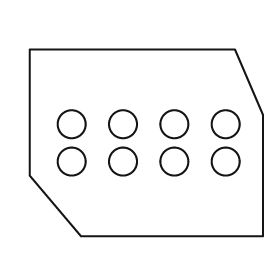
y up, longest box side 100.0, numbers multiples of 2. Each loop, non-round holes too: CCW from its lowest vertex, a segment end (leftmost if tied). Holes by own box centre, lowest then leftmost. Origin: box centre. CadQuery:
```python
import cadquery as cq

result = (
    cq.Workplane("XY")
    .moveTo(-28.0, -40.0)
    .lineTo(50.0, -40.0)
    .lineTo(50.0, 12.0)
    .lineTo(38.0, 40.0)
    .lineTo(-50.0, 40.0)
    .lineTo(-50.0, -14.0)
    .close()
    .moveTo(-32.0, -8.0)
    .circle(6.0)
    .moveTo(-10.0, -8.0)
    .circle(6.0)
    .moveTo(12.0, -8.0)
    .circle(6.0)
    .moveTo(34.0, -8.0)
    .circle(6.0)
    .moveTo(-32.0, 8.0)
    .circle(6.0)
    .moveTo(-10.0, 8.0)
    .circle(6.0)
    .moveTo(12.0, 8.0)
    .circle(6.0)
    .moveTo(34.0, 8.0)
    .circle(6.0)
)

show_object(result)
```